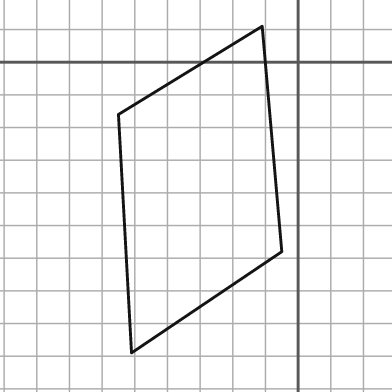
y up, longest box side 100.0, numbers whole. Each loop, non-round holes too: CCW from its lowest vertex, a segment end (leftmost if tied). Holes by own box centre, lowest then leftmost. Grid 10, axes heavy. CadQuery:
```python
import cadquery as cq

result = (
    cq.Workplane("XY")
    .moveTo(-51.0, -89.0)
    .lineTo(-5.0, -58.0)
    .lineTo(-11.0, 11.0)
    .lineTo(-55.0, -16.0)
    .close()
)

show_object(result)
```